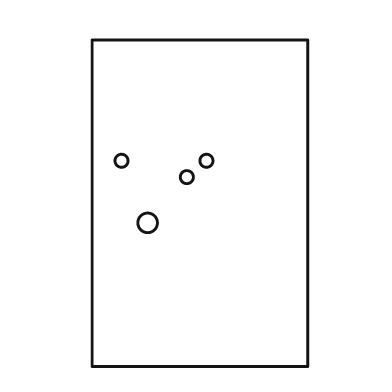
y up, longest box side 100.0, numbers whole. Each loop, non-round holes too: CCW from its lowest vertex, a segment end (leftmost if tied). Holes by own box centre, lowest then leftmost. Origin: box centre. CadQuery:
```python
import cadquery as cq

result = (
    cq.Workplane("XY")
    .moveTo(-33.0, -50.0)
    .lineTo(33.0, -50.0)
    .lineTo(33.0, 50.0)
    .lineTo(-33.0, 50.0)
    .close()
    .moveTo(-16.0, -6.0)
    .circle(3.0)
    .moveTo(-4.0, 8.0)
    .circle(2.0)
    .moveTo(-24.0, 13.0)
    .circle(2.0)
    .moveTo(2.0, 13.0)
    .circle(2.0)
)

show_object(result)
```